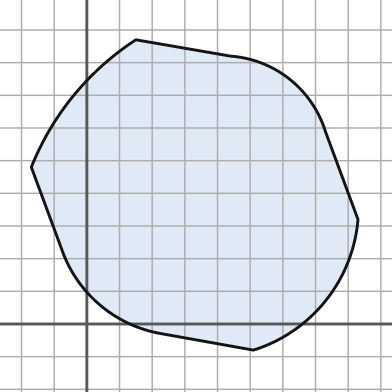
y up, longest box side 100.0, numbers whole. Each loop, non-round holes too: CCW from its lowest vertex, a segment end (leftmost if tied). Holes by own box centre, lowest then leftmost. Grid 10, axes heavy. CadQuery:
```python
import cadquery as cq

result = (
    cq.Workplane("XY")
    .moveTo(51.0, -8.0)
    .threePointArc((73.0, 7.0), (83.0, 32.0))
    .lineTo(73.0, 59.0)
    .threePointArc((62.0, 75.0), (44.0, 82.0))
    .lineTo(15.0, 87.0)
    .threePointArc((-4.0, 70.0), (-17.0, 48.0))
    .lineTo(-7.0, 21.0)
    .threePointArc((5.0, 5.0), (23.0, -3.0))
    .close()
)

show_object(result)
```